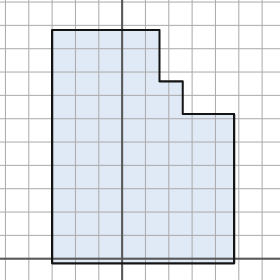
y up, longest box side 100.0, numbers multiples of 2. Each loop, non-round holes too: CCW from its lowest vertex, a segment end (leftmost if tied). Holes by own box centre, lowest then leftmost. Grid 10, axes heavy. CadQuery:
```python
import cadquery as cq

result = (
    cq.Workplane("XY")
    .moveTo(-30.0, -2.0)
    .lineTo(48.0, -2.0)
    .lineTo(48.0, 62.0)
    .lineTo(26.0, 62.0)
    .lineTo(26.0, 76.0)
    .lineTo(16.0, 76.0)
    .lineTo(16.0, 98.0)
    .lineTo(-30.0, 98.0)
    .close()
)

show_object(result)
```